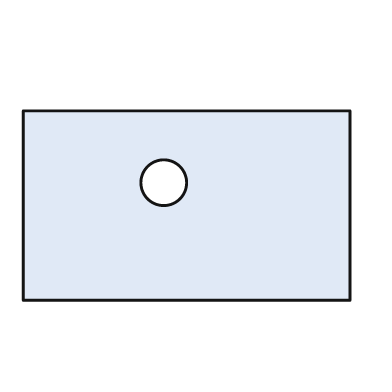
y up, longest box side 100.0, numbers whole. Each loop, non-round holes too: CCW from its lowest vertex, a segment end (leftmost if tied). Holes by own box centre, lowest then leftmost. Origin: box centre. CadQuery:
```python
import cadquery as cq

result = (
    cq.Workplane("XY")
    .moveTo(-50.0, -29.0)
    .lineTo(50.0, -29.0)
    .lineTo(50.0, 29.0)
    .lineTo(-50.0, 29.0)
    .close()
    .moveTo(-7.0, 7.0)
    .circle(7.0)
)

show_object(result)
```